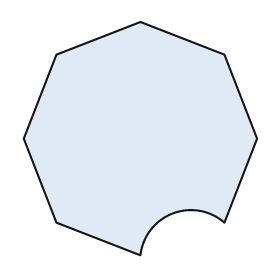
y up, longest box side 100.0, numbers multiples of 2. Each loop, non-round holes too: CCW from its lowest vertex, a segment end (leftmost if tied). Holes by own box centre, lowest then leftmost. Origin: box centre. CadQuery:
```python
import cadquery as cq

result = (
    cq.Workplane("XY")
    .moveTo(0.0, -50.0)
    .threePointArc((14.0, -32.0), (36.0, -36.0))
    .lineTo(50.0, 0.0)
    .lineTo(36.0, 36.0)
    .lineTo(0.0, 50.0)
    .lineTo(-36.0, 36.0)
    .lineTo(-50.0, 0.0)
    .lineTo(-36.0, -36.0)
    .close()
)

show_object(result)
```